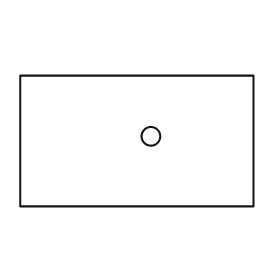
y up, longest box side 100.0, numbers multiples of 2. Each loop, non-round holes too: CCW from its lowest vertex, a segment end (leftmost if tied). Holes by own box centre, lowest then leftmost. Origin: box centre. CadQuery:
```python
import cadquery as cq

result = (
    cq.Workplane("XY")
    .moveTo(-50.0, -28.0)
    .lineTo(50.0, -28.0)
    .lineTo(50.0, 28.0)
    .lineTo(-50.0, 28.0)
    .close()
    .moveTo(6.0, 2.0)
    .circle(4.0)
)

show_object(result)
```